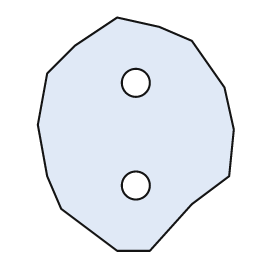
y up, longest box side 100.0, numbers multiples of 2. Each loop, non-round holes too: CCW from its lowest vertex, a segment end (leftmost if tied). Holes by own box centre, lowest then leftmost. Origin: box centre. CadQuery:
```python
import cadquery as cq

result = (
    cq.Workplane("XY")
    .moveTo(-8.0, -50.0)
    .lineTo(6.0, -50.0)
    .lineTo(24.0, -30.0)
    .lineTo(40.0, -18.0)
    .lineTo(42.0, 2.0)
    .lineTo(38.0, 20.0)
    .lineTo(24.0, 40.0)
    .lineTo(10.0, 46.0)
    .lineTo(-8.0, 50.0)
    .lineTo(-26.0, 38.0)
    .lineTo(-38.0, 26.0)
    .lineTo(-42.0, 4.0)
    .lineTo(-38.0, -18.0)
    .lineTo(-32.0, -32.0)
    .close()
    .moveTo(0.0, -22.0)
    .circle(6.0)
    .moveTo(0.0, 22.0)
    .circle(6.0)
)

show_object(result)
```